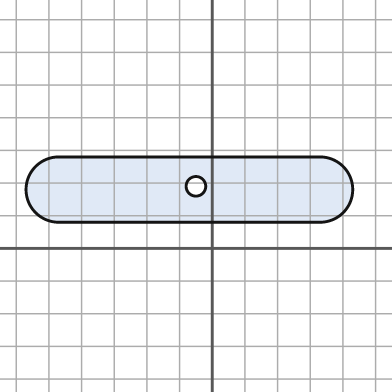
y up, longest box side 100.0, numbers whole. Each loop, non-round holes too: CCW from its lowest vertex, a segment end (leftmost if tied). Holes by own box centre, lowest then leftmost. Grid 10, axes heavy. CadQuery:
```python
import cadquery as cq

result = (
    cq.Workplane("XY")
    .moveTo(-47.0, 8.0)
    .lineTo(33.0, 8.0)
    .threePointArc((43.0, 18.0), (33.0, 28.0))
    .lineTo(-47.0, 28.0)
    .threePointArc((-57.0, 18.0), (-47.0, 8.0))
    .close()
    .moveTo(-5.0, 19.0)
    .circle(3.0)
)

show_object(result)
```